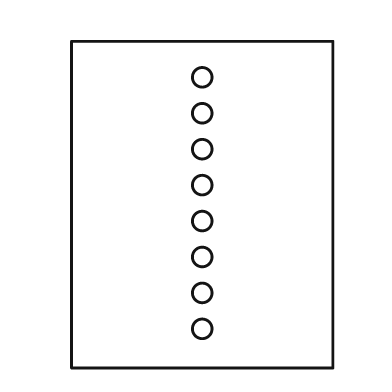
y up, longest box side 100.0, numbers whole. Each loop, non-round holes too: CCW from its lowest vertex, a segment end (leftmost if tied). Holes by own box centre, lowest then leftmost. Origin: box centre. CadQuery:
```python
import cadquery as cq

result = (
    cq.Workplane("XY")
    .moveTo(-40.0, -50.0)
    .lineTo(40.0, -50.0)
    .lineTo(40.0, 50.0)
    .lineTo(-40.0, 50.0)
    .close()
    .moveTo(0.0, -38.0)
    .circle(3.0)
    .moveTo(0.0, -27.0)
    .circle(3.0)
    .moveTo(0.0, -16.0)
    .circle(3.0)
    .moveTo(0.0, -5.0)
    .circle(3.0)
    .moveTo(0.0, 6.0)
    .circle(3.0)
    .moveTo(0.0, 17.0)
    .circle(3.0)
    .moveTo(0.0, 28.0)
    .circle(3.0)
    .moveTo(0.0, 39.0)
    .circle(3.0)
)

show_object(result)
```